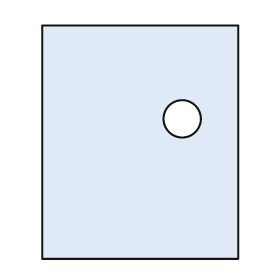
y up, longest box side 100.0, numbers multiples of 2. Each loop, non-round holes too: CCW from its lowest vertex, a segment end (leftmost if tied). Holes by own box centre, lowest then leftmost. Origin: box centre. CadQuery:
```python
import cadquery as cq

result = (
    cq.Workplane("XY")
    .moveTo(-42.0, -50.0)
    .lineTo(42.0, -50.0)
    .lineTo(42.0, 50.0)
    .lineTo(-42.0, 50.0)
    .close()
    .moveTo(18.0, 10.0)
    .circle(8.0)
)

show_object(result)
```